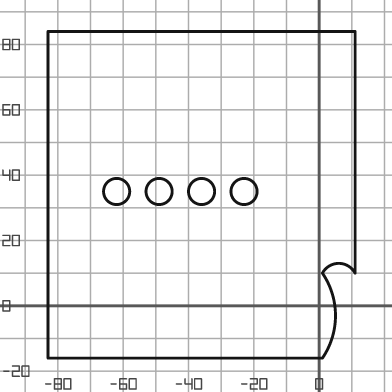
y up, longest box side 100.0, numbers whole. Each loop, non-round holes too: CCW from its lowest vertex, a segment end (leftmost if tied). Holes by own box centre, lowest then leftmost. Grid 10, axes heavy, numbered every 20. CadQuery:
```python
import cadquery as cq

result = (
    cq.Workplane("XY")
    .moveTo(-83.0, -16.0)
    .lineTo(1.0, -16.0)
    .threePointArc((5.0, -3.0), (1.0, 10.0))
    .threePointArc((6.0, 13.0), (11.0, 10.0))
    .lineTo(11.0, 84.0)
    .lineTo(-83.0, 84.0)
    .close()
    .moveTo(-62.0, 35.0)
    .circle(4.0)
    .moveTo(-49.0, 35.0)
    .circle(4.0)
    .moveTo(-36.0, 35.0)
    .circle(4.0)
    .moveTo(-23.0, 35.0)
    .circle(4.0)
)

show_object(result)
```